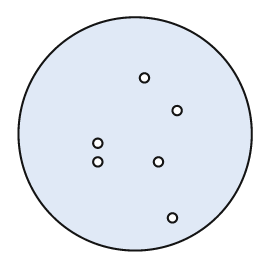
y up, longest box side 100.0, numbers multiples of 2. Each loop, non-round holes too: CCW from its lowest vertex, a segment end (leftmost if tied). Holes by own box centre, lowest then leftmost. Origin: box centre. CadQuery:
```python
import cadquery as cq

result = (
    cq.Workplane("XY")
    .moveTo(0.0, 0.0)
    .circle(50.0)
    .moveTo(16.0, -36.0)
    .circle(2.0)
    .moveTo(-16.0, -12.0)
    .circle(2.0)
    .moveTo(10.0, -12.0)
    .circle(2.0)
    .moveTo(-16.0, -4.0)
    .circle(2.0)
    .moveTo(18.0, 10.0)
    .circle(2.0)
    .moveTo(4.0, 24.0)
    .circle(2.0)
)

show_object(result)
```